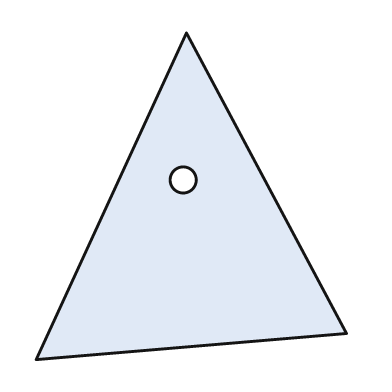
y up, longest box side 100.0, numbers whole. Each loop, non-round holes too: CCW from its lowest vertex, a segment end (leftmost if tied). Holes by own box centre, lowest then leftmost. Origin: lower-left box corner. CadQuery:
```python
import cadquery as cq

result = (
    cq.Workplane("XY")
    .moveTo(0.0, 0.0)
    .lineTo(95.0, 8.0)
    .lineTo(46.0, 100.0)
    .close()
    .moveTo(45.0, 55.0)
    .circle(4.0)
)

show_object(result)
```